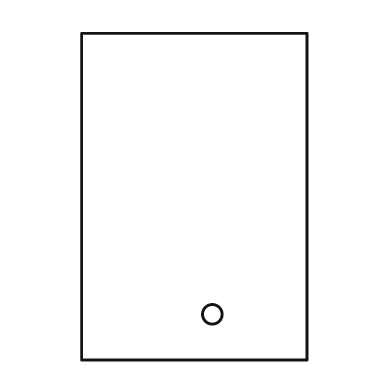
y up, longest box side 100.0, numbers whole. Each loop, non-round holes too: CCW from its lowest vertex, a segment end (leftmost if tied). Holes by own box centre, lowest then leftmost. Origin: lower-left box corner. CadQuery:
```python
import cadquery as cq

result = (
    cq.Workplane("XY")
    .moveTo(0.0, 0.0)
    .lineTo(69.0, 0.0)
    .lineTo(69.0, 100.0)
    .lineTo(0.0, 100.0)
    .close()
    .moveTo(40.0, 14.0)
    .circle(3.0)
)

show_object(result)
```